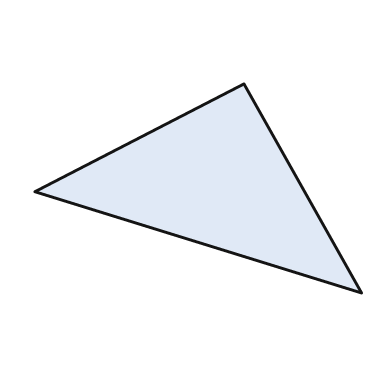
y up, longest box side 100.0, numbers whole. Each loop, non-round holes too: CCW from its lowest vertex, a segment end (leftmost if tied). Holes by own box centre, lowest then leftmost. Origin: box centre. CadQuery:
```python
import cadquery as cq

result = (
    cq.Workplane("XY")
    .moveTo(50.0, -32.0)
    .lineTo(14.0, 32.0)
    .lineTo(-50.0, -1.0)
    .close()
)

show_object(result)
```